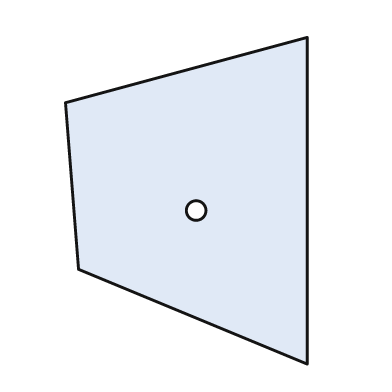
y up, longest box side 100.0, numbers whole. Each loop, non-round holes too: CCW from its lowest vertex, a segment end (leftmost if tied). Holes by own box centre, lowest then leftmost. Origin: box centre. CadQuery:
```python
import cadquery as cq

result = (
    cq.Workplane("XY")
    .moveTo(37.0, -50.0)
    .lineTo(37.0, 50.0)
    .lineTo(-37.0, 30.0)
    .lineTo(-33.0, -21.0)
    .close()
    .moveTo(3.0, -3.0)
    .circle(3.0)
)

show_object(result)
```